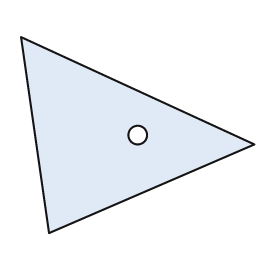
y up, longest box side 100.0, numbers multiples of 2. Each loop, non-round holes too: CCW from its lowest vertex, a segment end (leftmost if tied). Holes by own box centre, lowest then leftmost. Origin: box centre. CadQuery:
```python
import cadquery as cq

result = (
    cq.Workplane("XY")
    .moveTo(-38.0, -42.0)
    .lineTo(50.0, -4.0)
    .lineTo(-50.0, 42.0)
    .close()
    .moveTo(0.0, 0.0)
    .circle(4.0)
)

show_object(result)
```